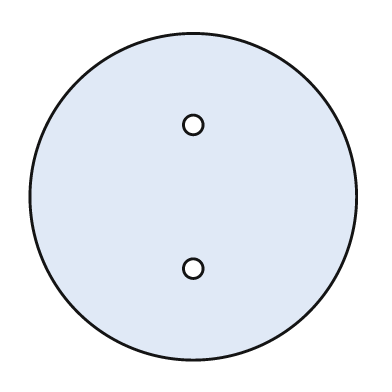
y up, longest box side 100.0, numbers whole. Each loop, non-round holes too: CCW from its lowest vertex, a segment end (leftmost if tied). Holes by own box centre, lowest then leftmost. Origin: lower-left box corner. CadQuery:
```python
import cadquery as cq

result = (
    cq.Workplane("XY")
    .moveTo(50.0, 50.0)
    .circle(50.0)
    .moveTo(50.0, 28.0)
    .circle(3.0)
    .moveTo(50.0, 72.0)
    .circle(3.0)
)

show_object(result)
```